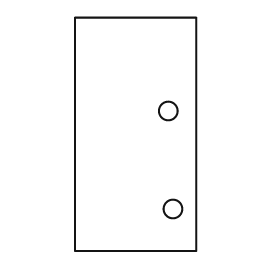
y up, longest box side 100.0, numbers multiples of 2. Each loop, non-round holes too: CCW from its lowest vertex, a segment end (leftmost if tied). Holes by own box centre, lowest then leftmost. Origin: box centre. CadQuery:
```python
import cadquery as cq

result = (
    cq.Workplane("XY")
    .moveTo(-26.0, -50.0)
    .lineTo(26.0, -50.0)
    .lineTo(26.0, 50.0)
    .lineTo(-26.0, 50.0)
    .close()
    .moveTo(16.0, -32.0)
    .circle(4.0)
    .moveTo(14.0, 10.0)
    .circle(4.0)
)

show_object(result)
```